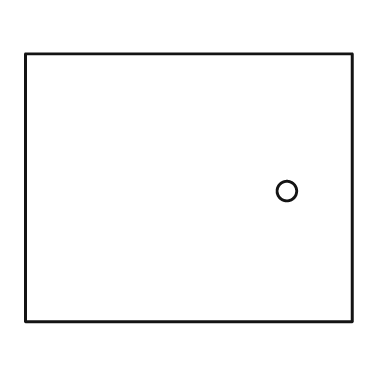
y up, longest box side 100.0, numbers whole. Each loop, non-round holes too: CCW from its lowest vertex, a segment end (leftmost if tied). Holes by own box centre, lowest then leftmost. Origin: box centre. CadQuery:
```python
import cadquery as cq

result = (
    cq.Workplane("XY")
    .moveTo(-50.0, -41.0)
    .lineTo(50.0, -41.0)
    .lineTo(50.0, 41.0)
    .lineTo(-50.0, 41.0)
    .close()
    .moveTo(30.0, -1.0)
    .circle(3.0)
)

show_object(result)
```